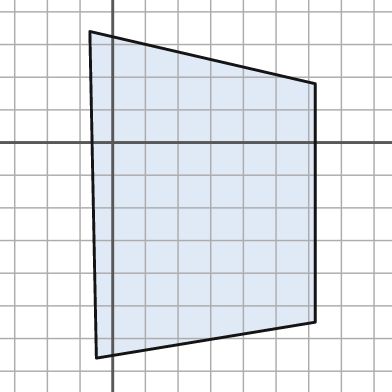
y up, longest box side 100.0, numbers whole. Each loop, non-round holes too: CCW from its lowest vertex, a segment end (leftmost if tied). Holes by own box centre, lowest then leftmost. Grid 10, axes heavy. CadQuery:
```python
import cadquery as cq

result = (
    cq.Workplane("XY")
    .moveTo(-5.0, -66.0)
    .lineTo(62.0, -55.0)
    .lineTo(62.0, 18.0)
    .lineTo(-7.0, 34.0)
    .close()
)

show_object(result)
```